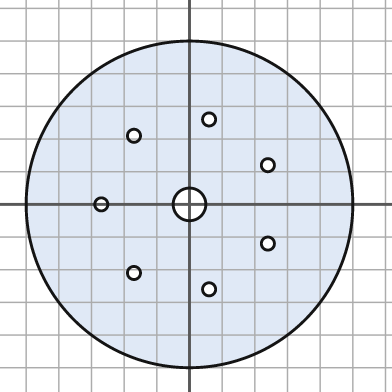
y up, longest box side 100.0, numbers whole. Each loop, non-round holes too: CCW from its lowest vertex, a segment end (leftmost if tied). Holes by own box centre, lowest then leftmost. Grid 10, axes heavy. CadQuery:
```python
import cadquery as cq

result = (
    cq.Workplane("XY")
    .moveTo(0.0, 0.0)
    .circle(50.0)
    .moveTo(6.0, -26.0)
    .circle(2.0)
    .moveTo(-17.0, -21.0)
    .circle(2.0)
    .moveTo(24.0, -12.0)
    .circle(2.0)
    .moveTo(-27.0, 0.0)
    .circle(2.0)
    .moveTo(0.0, 0.0)
    .circle(5.0)
    .moveTo(24.0, 12.0)
    .circle(2.0)
    .moveTo(-17.0, 21.0)
    .circle(2.0)
    .moveTo(6.0, 26.0)
    .circle(2.0)
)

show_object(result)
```